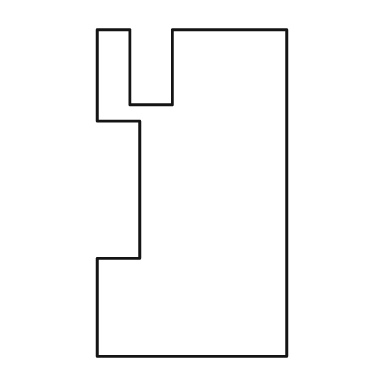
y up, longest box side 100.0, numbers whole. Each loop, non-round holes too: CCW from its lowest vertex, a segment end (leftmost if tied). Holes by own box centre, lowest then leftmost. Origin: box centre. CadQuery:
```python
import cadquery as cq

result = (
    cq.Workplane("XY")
    .moveTo(-29.0, -50.0)
    .lineTo(29.0, -50.0)
    .lineTo(29.0, 50.0)
    .lineTo(-6.0, 50.0)
    .lineTo(-6.0, 27.0)
    .lineTo(-19.0, 27.0)
    .lineTo(-19.0, 50.0)
    .lineTo(-29.0, 50.0)
    .lineTo(-29.0, 22.0)
    .lineTo(-16.0, 22.0)
    .lineTo(-16.0, -20.0)
    .lineTo(-29.0, -20.0)
    .close()
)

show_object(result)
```